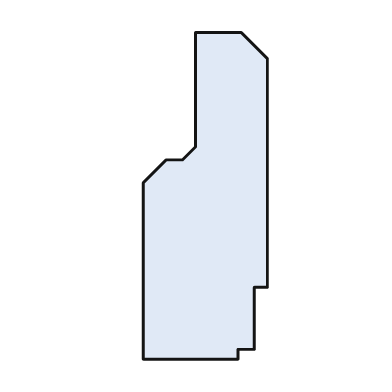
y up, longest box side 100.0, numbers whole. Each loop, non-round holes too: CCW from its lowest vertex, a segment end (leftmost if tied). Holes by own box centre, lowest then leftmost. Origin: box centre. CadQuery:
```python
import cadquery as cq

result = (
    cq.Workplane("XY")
    .moveTo(-19.0, -50.0)
    .lineTo(10.0, -50.0)
    .lineTo(10.0, -47.0)
    .lineTo(15.0, -47.0)
    .lineTo(15.0, -28.0)
    .lineTo(19.0, -28.0)
    .lineTo(19.0, 42.0)
    .lineTo(11.0, 50.0)
    .lineTo(-3.0, 50.0)
    .lineTo(-3.0, 15.0)
    .lineTo(-7.0, 11.0)
    .lineTo(-12.0, 11.0)
    .lineTo(-19.0, 4.0)
    .close()
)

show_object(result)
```